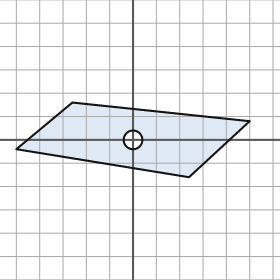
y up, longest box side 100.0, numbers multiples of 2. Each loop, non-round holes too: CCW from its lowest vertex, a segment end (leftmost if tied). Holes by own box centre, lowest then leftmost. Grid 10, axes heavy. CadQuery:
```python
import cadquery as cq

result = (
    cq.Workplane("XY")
    .moveTo(24.0, -16.0)
    .lineTo(50.0, 8.0)
    .lineTo(-26.0, 16.0)
    .lineTo(-50.0, -4.0)
    .close()
    .moveTo(0.0, 0.0)
    .circle(4.0)
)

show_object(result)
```